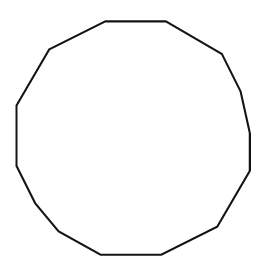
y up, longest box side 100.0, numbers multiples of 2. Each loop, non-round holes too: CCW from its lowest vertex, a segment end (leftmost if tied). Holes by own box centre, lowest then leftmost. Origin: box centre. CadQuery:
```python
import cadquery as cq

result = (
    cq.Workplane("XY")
    .moveTo(-14.0, -50.0)
    .lineTo(12.0, -50.0)
    .lineTo(36.0, -38.0)
    .lineTo(50.0, -14.0)
    .lineTo(50.0, 2.0)
    .lineTo(46.0, 20.0)
    .lineTo(38.0, 36.0)
    .lineTo(14.0, 50.0)
    .lineTo(-12.0, 50.0)
    .lineTo(-36.0, 38.0)
    .lineTo(-50.0, 14.0)
    .lineTo(-50.0, -12.0)
    .lineTo(-42.0, -28.0)
    .lineTo(-32.0, -40.0)
    .close()
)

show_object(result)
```